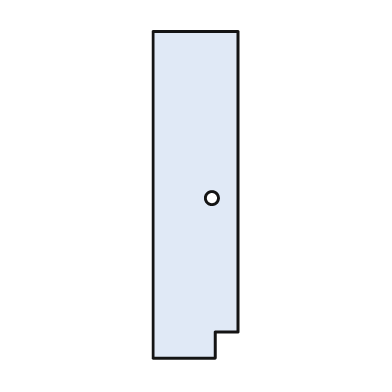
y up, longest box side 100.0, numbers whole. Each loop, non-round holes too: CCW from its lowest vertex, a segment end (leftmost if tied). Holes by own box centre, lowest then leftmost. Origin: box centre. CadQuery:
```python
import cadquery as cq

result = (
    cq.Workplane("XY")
    .moveTo(-13.0, -50.0)
    .lineTo(6.0, -50.0)
    .lineTo(6.0, -42.0)
    .lineTo(13.0, -42.0)
    .lineTo(13.0, 50.0)
    .lineTo(-13.0, 50.0)
    .close()
    .moveTo(5.0, -1.0)
    .circle(2.0)
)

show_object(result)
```